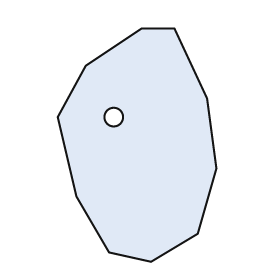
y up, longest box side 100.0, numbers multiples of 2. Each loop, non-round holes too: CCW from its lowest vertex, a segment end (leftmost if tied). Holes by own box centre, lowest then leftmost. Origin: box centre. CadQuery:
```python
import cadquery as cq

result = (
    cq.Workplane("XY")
    .moveTo(6.0, -50.0)
    .lineTo(26.0, -38.0)
    .lineTo(34.0, -10.0)
    .lineTo(30.0, 20.0)
    .lineTo(16.0, 50.0)
    .lineTo(2.0, 50.0)
    .lineTo(-22.0, 34.0)
    .lineTo(-34.0, 12.0)
    .lineTo(-26.0, -22.0)
    .lineTo(-12.0, -46.0)
    .close()
    .moveTo(-10.0, 12.0)
    .circle(4.0)
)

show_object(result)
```